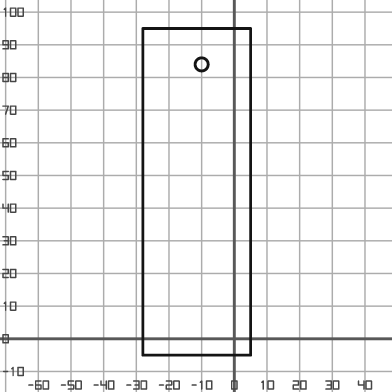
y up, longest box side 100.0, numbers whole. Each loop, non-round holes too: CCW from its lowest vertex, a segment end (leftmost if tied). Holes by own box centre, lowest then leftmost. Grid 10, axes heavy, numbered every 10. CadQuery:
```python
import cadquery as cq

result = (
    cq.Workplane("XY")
    .moveTo(-28.0, -5.0)
    .lineTo(5.0, -5.0)
    .lineTo(5.0, 95.0)
    .lineTo(-28.0, 95.0)
    .close()
    .moveTo(-10.0, 84.0)
    .circle(2.0)
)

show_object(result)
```